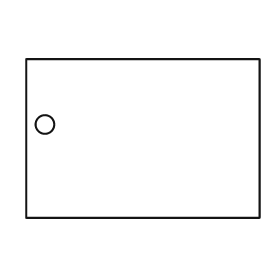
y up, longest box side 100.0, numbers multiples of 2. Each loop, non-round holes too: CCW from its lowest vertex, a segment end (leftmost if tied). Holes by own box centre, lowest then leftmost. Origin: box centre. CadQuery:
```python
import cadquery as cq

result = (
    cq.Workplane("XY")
    .moveTo(-50.0, -34.0)
    .lineTo(50.0, -34.0)
    .lineTo(50.0, 34.0)
    .lineTo(-50.0, 34.0)
    .close()
    .moveTo(-42.0, 6.0)
    .circle(4.0)
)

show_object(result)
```